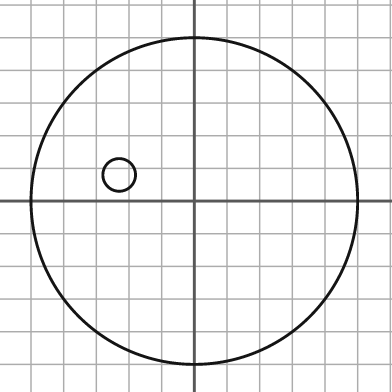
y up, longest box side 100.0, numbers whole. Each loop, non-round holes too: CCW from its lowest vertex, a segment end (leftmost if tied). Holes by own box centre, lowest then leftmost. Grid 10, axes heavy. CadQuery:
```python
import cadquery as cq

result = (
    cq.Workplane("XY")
    .moveTo(0.0, 0.0)
    .circle(50.0)
    .moveTo(-23.0, 8.0)
    .circle(5.0)
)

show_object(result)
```